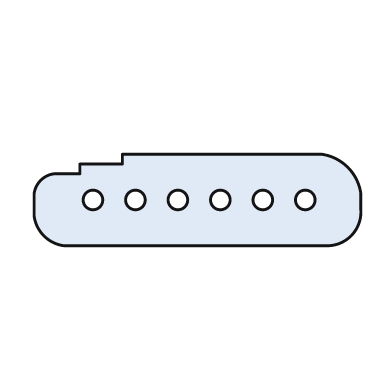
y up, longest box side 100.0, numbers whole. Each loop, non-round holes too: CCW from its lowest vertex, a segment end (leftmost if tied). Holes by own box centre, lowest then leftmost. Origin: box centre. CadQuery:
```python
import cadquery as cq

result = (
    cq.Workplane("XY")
    .moveTo(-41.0, -14.0)
    .lineTo(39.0, -14.0)
    .threePointArc((47.0, -11.0), (50.0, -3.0))
    .lineTo(50.0, 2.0)
    .threePointArc((46.0, 10.0), (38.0, 14.0))
    .lineTo(-23.0, 14.0)
    .lineTo(-23.0, 11.0)
    .lineTo(-36.0, 11.0)
    .lineTo(-36.0, 8.0)
    .lineTo(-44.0, 8.0)
    .threePointArc((-48.0, 6.0), (-50.0, 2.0))
    .lineTo(-50.0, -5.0)
    .threePointArc((-47.0, -11.0), (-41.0, -14.0))
    .close()
    .moveTo(-32.0, 0.0)
    .circle(3.0)
    .moveTo(-19.0, 0.0)
    .circle(3.0)
    .moveTo(-6.0, 0.0)
    .circle(3.0)
    .moveTo(7.0, 0.0)
    .circle(3.0)
    .moveTo(20.0, 0.0)
    .circle(3.0)
    .moveTo(33.0, 0.0)
    .circle(3.0)
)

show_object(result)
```